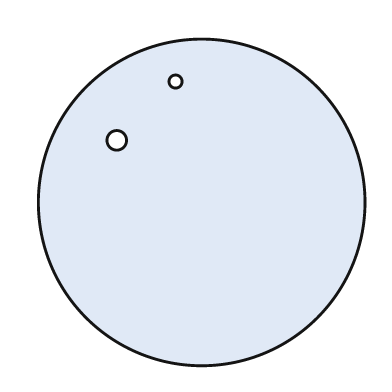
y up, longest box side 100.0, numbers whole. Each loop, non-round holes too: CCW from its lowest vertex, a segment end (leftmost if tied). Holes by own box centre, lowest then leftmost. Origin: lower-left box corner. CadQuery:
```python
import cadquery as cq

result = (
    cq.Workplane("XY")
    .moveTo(50.0, 50.0)
    .circle(50.0)
    .moveTo(24.0, 69.0)
    .circle(3.0)
    .moveTo(42.0, 87.0)
    .circle(2.0)
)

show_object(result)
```